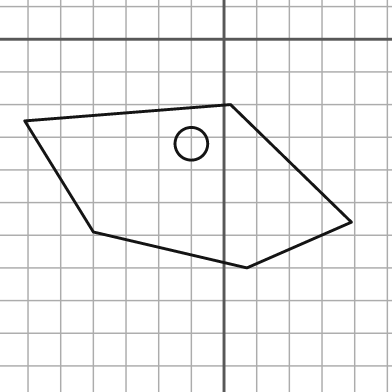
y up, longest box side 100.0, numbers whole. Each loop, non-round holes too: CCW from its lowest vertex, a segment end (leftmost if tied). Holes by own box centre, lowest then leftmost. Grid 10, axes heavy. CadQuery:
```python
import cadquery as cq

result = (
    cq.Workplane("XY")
    .moveTo(7.0, -70.0)
    .lineTo(39.0, -56.0)
    .lineTo(2.0, -20.0)
    .lineTo(-61.0, -25.0)
    .lineTo(-40.0, -59.0)
    .close()
    .moveTo(-10.0, -32.0)
    .circle(5.0)
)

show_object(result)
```